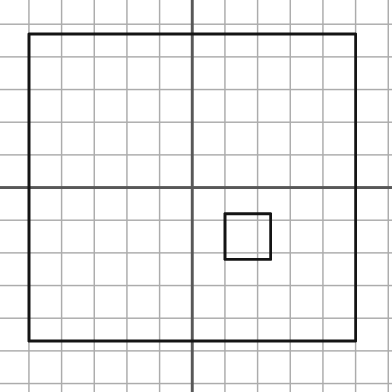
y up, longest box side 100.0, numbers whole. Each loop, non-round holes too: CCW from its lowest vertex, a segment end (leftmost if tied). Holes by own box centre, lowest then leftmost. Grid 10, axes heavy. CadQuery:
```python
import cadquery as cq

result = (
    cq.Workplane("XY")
    .moveTo(-50.0, -47.0)
    .lineTo(50.0, -47.0)
    .lineTo(50.0, 47.0)
    .lineTo(-50.0, 47.0)
    .close()
    .moveTo(10.0, -22.0)
    .lineTo(24.0, -22.0)
    .lineTo(24.0, -8.0)
    .lineTo(10.0, -8.0)
    .close()
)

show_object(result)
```